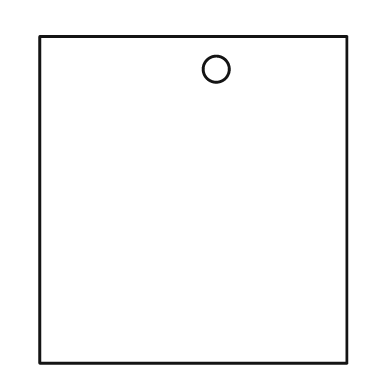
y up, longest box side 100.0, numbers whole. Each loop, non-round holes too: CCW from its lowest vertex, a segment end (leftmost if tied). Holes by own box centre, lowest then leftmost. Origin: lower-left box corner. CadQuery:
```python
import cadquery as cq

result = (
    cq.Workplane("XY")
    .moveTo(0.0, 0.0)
    .lineTo(94.0, 0.0)
    .lineTo(94.0, 100.0)
    .lineTo(0.0, 100.0)
    .close()
    .moveTo(54.0, 90.0)
    .circle(4.0)
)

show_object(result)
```